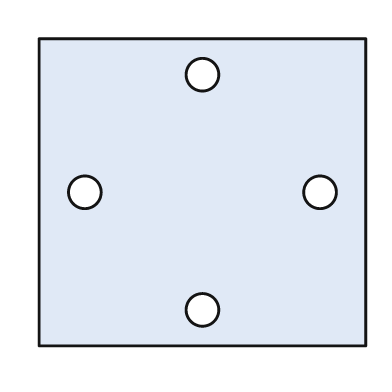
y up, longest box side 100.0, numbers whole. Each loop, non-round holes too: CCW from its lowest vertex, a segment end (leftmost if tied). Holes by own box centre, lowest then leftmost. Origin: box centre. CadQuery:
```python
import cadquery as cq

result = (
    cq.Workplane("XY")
    .moveTo(-50.0, -47.0)
    .lineTo(50.0, -47.0)
    .lineTo(50.0, 47.0)
    .lineTo(-50.0, 47.0)
    .close()
    .moveTo(0.0, -36.0)
    .circle(5.0)
    .moveTo(-36.0, 0.0)
    .circle(5.0)
    .moveTo(36.0, 0.0)
    .circle(5.0)
    .moveTo(0.0, 36.0)
    .circle(5.0)
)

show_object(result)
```